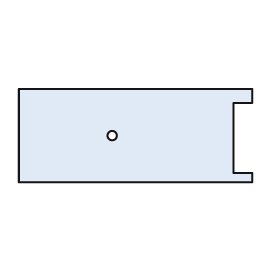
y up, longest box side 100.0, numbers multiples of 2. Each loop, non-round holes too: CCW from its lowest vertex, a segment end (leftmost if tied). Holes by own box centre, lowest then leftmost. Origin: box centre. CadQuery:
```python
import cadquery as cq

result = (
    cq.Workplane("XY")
    .moveTo(-50.0, -20.0)
    .lineTo(50.0, -20.0)
    .lineTo(50.0, -16.0)
    .lineTo(42.0, -16.0)
    .lineTo(42.0, 14.0)
    .lineTo(50.0, 14.0)
    .lineTo(50.0, 20.0)
    .lineTo(-50.0, 20.0)
    .close()
    .moveTo(-10.0, 0.0)
    .circle(2.0)
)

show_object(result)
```